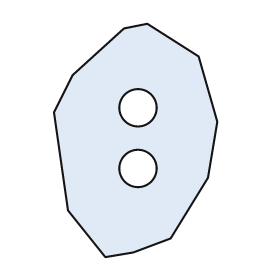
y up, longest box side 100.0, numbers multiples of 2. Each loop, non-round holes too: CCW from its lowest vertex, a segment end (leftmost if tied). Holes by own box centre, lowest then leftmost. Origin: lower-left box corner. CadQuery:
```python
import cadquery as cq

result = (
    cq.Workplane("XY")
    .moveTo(22.0, 0.0)
    .lineTo(34.0, 2.0)
    .lineTo(50.0, 8.0)
    .lineTo(66.0, 34.0)
    .lineTo(70.0, 58.0)
    .lineTo(62.0, 86.0)
    .lineTo(40.0, 100.0)
    .lineTo(30.0, 98.0)
    .lineTo(8.0, 78.0)
    .lineTo(0.0, 62.0)
    .lineTo(6.0, 20.0)
    .close()
    .moveTo(36.0, 38.0)
    .circle(8.0)
    .moveTo(36.0, 64.0)
    .circle(8.0)
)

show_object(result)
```